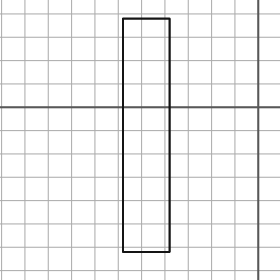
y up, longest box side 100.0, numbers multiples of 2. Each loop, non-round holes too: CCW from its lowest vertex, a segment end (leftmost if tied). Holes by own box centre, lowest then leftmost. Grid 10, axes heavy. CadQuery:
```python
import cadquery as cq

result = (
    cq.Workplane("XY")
    .moveTo(-58.0, -62.0)
    .lineTo(-38.0, -62.0)
    .lineTo(-38.0, 38.0)
    .lineTo(-58.0, 38.0)
    .close()
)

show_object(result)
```